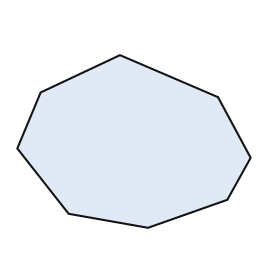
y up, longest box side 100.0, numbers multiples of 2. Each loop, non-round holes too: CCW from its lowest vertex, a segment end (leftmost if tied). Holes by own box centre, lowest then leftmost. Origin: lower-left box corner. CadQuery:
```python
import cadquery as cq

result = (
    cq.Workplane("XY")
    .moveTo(56.0, 0.0)
    .lineTo(90.0, 12.0)
    .lineTo(100.0, 30.0)
    .lineTo(86.0, 56.0)
    .lineTo(44.0, 74.0)
    .lineTo(10.0, 58.0)
    .lineTo(0.0, 34.0)
    .lineTo(22.0, 6.0)
    .close()
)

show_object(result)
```